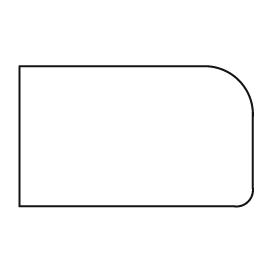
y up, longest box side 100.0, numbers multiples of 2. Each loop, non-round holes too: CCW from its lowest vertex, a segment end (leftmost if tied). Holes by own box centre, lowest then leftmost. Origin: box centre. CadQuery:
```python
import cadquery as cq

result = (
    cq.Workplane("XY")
    .moveTo(-50.0, -30.0)
    .lineTo(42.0, -30.0)
    .threePointArc((48.0, -28.0), (50.0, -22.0))
    .lineTo(50.0, 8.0)
    .threePointArc((44.0, 24.0), (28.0, 30.0))
    .lineTo(-50.0, 30.0)
    .close()
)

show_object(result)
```